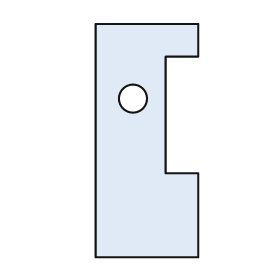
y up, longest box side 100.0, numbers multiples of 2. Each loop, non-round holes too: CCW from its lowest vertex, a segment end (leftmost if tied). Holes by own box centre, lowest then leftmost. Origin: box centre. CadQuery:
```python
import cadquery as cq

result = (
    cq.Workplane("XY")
    .moveTo(-22.0, -50.0)
    .lineTo(22.0, -50.0)
    .lineTo(22.0, -14.0)
    .lineTo(8.0, -14.0)
    .lineTo(8.0, 36.0)
    .lineTo(22.0, 36.0)
    .lineTo(22.0, 50.0)
    .lineTo(-22.0, 50.0)
    .close()
    .moveTo(-6.0, 18.0)
    .circle(6.0)
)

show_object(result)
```